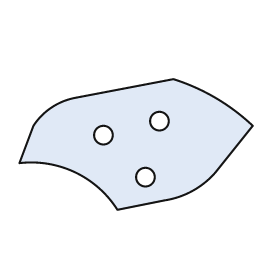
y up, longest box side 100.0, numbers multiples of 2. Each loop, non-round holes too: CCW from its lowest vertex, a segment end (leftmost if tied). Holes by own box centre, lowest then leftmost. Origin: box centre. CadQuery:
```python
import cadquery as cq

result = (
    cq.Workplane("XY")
    .moveTo(-8.0, -28.0)
    .lineTo(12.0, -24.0)
    .threePointArc((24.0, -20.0), (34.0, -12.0))
    .lineTo(50.0, 8.0)
    .threePointArc((34.0, 20.0), (16.0, 28.0))
    .lineTo(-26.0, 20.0)
    .threePointArc((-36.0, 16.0), (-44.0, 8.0))
    .lineTo(-50.0, -8.0)
    .threePointArc((-26.0, -12.0), (-8.0, -28.0))
    .close()
    .moveTo(4.0, -14.0)
    .circle(4.0)
    .moveTo(-14.0, 4.0)
    .circle(4.0)
    .moveTo(10.0, 10.0)
    .circle(4.0)
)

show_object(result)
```